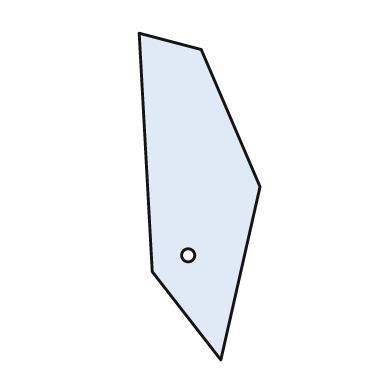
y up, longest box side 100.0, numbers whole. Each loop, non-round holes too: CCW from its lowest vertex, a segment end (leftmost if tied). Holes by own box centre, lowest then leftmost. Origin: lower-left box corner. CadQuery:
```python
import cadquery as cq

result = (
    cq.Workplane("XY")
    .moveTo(25.0, 0.0)
    .lineTo(37.0, 53.0)
    .lineTo(19.0, 95.0)
    .lineTo(0.0, 100.0)
    .lineTo(4.0, 27.0)
    .close()
    .moveTo(15.0, 32.0)
    .circle(2.0)
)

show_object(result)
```